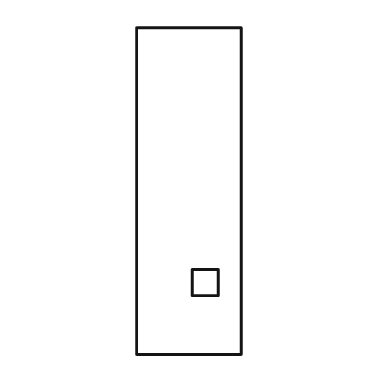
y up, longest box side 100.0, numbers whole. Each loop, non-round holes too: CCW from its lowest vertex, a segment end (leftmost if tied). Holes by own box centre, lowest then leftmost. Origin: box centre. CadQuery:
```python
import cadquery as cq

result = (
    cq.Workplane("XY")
    .moveTo(-16.0, -50.0)
    .lineTo(16.0, -50.0)
    .lineTo(16.0, 50.0)
    .lineTo(-16.0, 50.0)
    .close()
    .moveTo(1.0, -32.0)
    .lineTo(9.0, -32.0)
    .lineTo(9.0, -24.0)
    .lineTo(1.0, -24.0)
    .close()
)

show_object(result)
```